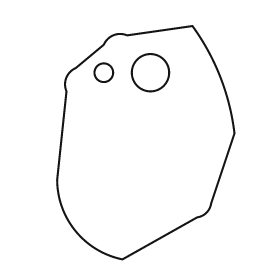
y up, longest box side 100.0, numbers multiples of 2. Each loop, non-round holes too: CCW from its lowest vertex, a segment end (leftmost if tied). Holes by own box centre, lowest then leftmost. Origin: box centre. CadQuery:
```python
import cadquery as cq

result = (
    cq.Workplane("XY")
    .moveTo(-10.0, -50.0)
    .lineTo(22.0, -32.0)
    .threePointArc((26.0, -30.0), (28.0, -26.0))
    .lineTo(38.0, 4.0)
    .threePointArc((32.0, 28.0), (20.0, 50.0))
    .lineTo(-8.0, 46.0)
    .threePointArc((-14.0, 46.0), (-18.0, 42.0))
    .lineTo(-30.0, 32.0)
    .threePointArc((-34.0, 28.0), (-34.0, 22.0))
    .lineTo(-38.0, -16.0)
    .threePointArc((-30.0, -38.0), (-10.0, -50.0))
    .close()
    .moveTo(-18.0, 30.0)
    .circle(4.0)
    .moveTo(2.0, 30.0)
    .circle(8.0)
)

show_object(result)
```